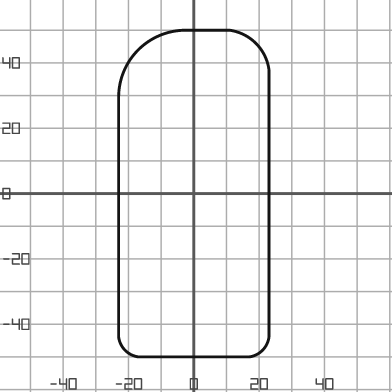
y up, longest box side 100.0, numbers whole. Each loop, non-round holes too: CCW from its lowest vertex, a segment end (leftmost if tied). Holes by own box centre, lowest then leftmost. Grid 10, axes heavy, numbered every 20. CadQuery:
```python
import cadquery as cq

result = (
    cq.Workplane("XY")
    .moveTo(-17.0, -50.0)
    .lineTo(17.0, -50.0)
    .threePointArc((21.0, -48.0), (23.0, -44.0))
    .lineTo(23.0, 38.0)
    .threePointArc((19.0, 46.0), (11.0, 50.0))
    .lineTo(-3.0, 50.0)
    .threePointArc((-17.0, 44.0), (-23.0, 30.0))
    .lineTo(-23.0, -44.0)
    .threePointArc((-21.0, -48.0), (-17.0, -50.0))
    .close()
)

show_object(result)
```